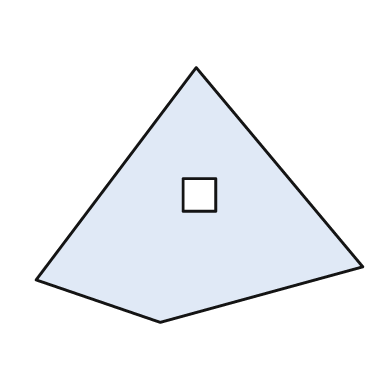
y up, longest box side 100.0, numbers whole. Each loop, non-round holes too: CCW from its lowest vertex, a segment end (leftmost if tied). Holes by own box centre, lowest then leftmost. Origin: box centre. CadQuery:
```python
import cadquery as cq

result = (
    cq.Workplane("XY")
    .moveTo(-12.0, -39.0)
    .lineTo(50.0, -22.0)
    .lineTo(-1.0, 39.0)
    .lineTo(-50.0, -26.0)
    .close()
    .moveTo(-5.0, -5.0)
    .lineTo(5.0, -5.0)
    .lineTo(5.0, 5.0)
    .lineTo(-5.0, 5.0)
    .close()
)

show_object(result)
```